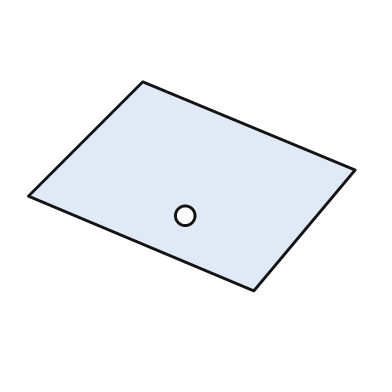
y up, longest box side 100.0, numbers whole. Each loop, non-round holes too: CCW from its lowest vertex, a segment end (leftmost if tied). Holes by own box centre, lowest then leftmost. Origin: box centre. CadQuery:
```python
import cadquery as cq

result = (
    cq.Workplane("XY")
    .moveTo(19.0, -32.0)
    .lineTo(50.0, 5.0)
    .lineTo(-15.0, 32.0)
    .lineTo(-50.0, -3.0)
    .close()
    .moveTo(-2.0, -9.0)
    .circle(3.0)
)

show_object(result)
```